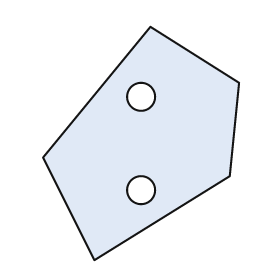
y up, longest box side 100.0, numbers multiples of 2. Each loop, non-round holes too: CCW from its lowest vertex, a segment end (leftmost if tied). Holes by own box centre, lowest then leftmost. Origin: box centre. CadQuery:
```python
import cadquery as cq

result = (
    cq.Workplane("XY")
    .moveTo(-20.0, -50.0)
    .lineTo(38.0, -14.0)
    .lineTo(42.0, 26.0)
    .lineTo(4.0, 50.0)
    .lineTo(-42.0, -6.0)
    .close()
    .moveTo(0.0, -20.0)
    .circle(6.0)
    .moveTo(0.0, 20.0)
    .circle(6.0)
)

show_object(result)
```